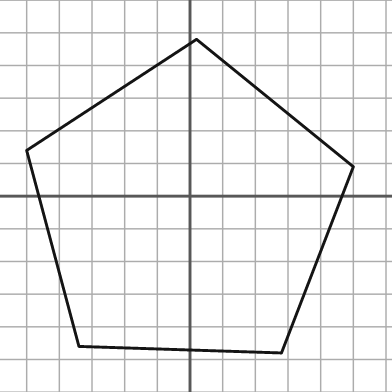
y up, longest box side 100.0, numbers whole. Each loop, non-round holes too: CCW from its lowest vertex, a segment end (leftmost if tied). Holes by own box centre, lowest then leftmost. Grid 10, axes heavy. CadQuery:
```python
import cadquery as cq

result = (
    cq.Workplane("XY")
    .moveTo(28.0, -48.0)
    .lineTo(50.0, 9.0)
    .lineTo(2.0, 48.0)
    .lineTo(-50.0, 14.0)
    .lineTo(-34.0, -46.0)
    .close()
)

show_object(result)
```